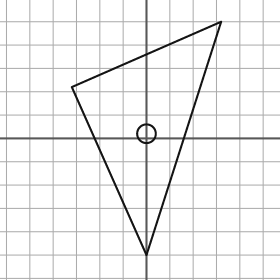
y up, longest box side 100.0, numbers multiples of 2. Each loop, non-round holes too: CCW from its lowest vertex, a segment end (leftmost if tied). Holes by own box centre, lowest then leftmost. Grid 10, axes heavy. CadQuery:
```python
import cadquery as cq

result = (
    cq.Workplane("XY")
    .moveTo(0.0, -50.0)
    .lineTo(32.0, 50.0)
    .lineTo(-32.0, 22.0)
    .close()
    .moveTo(0.0, 2.0)
    .circle(4.0)
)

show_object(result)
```